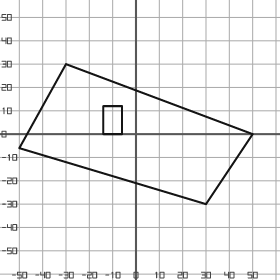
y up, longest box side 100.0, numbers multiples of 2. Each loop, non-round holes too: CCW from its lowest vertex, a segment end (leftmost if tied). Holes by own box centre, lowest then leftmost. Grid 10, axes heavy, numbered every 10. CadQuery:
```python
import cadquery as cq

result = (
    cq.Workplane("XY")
    .moveTo(30.0, -30.0)
    .lineTo(50.0, 0.0)
    .lineTo(-30.0, 30.0)
    .lineTo(-50.0, -6.0)
    .close()
    .moveTo(-14.0, 0.0)
    .lineTo(-6.0, 0.0)
    .lineTo(-6.0, 12.0)
    .lineTo(-14.0, 12.0)
    .close()
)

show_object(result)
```